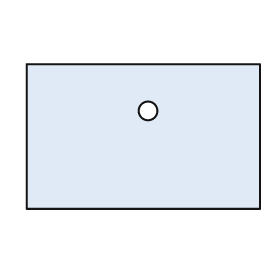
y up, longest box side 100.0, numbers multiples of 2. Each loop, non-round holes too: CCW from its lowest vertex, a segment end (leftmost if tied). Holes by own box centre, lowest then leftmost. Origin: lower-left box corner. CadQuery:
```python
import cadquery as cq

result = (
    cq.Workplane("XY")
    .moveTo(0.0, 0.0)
    .lineTo(100.0, 0.0)
    .lineTo(100.0, 62.0)
    .lineTo(0.0, 62.0)
    .close()
    .moveTo(52.0, 42.0)
    .circle(4.0)
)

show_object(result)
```